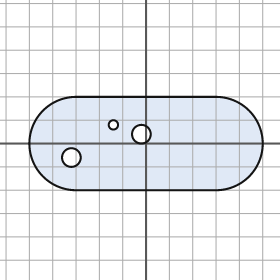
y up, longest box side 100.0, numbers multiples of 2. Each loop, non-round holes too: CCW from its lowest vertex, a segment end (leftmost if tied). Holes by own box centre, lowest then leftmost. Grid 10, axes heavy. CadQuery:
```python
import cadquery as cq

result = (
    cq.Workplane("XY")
    .moveTo(-30.0, -20.0)
    .lineTo(30.0, -20.0)
    .threePointArc((50.0, 0.0), (30.0, 20.0))
    .lineTo(-30.0, 20.0)
    .threePointArc((-50.0, 0.0), (-30.0, -20.0))
    .close()
    .moveTo(-32.0, -6.0)
    .circle(4.0)
    .moveTo(-2.0, 4.0)
    .circle(4.0)
    .moveTo(-14.0, 8.0)
    .circle(2.0)
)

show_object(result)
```